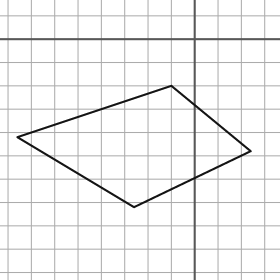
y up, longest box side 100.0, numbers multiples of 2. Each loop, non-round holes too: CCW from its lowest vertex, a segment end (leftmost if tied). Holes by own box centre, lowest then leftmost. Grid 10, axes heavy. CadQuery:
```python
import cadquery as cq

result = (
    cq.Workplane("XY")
    .moveTo(-26.0, -72.0)
    .lineTo(24.0, -48.0)
    .lineTo(-10.0, -20.0)
    .lineTo(-76.0, -42.0)
    .close()
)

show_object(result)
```